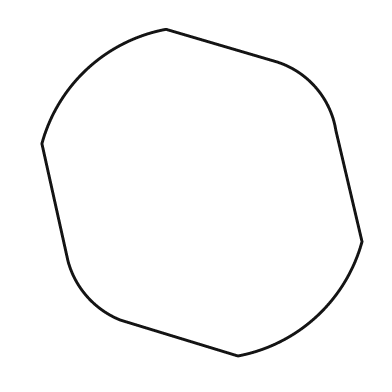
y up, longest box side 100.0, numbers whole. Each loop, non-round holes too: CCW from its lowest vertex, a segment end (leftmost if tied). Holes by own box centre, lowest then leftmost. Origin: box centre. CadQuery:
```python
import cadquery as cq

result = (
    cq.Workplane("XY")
    .moveTo(11.0, -50.0)
    .threePointArc((35.0, -38.0), (49.0, -15.0))
    .lineTo(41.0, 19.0)
    .threePointArc((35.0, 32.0), (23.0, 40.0))
    .lineTo(-11.0, 50.0)
    .threePointArc((-35.0, 38.0), (-49.0, 15.0))
    .lineTo(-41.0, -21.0)
    .threePointArc((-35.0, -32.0), (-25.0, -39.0))
    .close()
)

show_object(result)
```